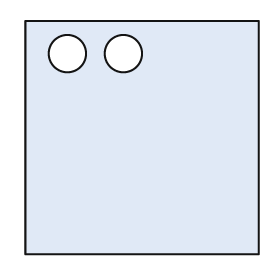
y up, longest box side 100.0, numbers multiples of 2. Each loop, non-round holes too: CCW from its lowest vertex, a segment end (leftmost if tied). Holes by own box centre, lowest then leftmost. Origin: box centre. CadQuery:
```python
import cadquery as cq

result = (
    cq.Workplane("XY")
    .moveTo(-50.0, -50.0)
    .lineTo(50.0, -50.0)
    .lineTo(50.0, 50.0)
    .lineTo(-50.0, 50.0)
    .close()
    .moveTo(-32.0, 36.0)
    .circle(8.0)
    .moveTo(-8.0, 36.0)
    .circle(8.0)
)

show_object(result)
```